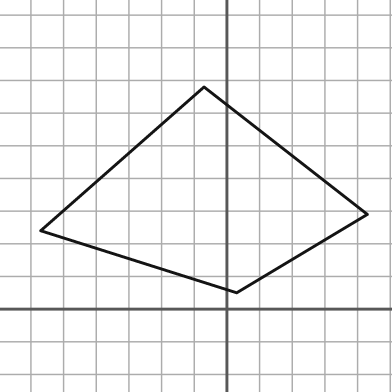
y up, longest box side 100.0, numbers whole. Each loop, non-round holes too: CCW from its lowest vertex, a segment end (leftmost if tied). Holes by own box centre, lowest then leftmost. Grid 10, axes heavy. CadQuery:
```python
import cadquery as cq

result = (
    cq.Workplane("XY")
    .moveTo(3.0, 5.0)
    .lineTo(43.0, 29.0)
    .lineTo(-7.0, 68.0)
    .lineTo(-57.0, 24.0)
    .close()
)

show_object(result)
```